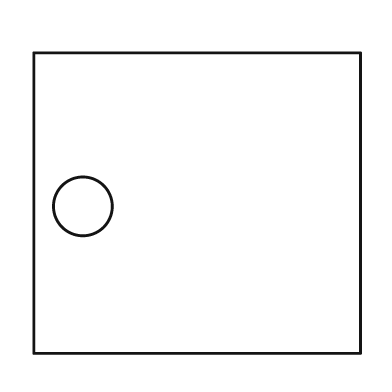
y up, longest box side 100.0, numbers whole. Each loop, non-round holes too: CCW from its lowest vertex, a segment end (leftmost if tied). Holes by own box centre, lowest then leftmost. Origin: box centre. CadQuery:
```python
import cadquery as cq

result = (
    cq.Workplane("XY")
    .moveTo(-50.0, -46.0)
    .lineTo(50.0, -46.0)
    .lineTo(50.0, 46.0)
    .lineTo(-50.0, 46.0)
    .close()
    .moveTo(-35.0, -1.0)
    .circle(9.0)
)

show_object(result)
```